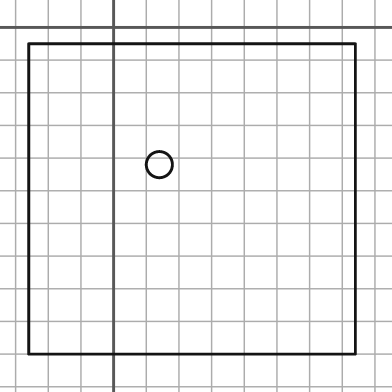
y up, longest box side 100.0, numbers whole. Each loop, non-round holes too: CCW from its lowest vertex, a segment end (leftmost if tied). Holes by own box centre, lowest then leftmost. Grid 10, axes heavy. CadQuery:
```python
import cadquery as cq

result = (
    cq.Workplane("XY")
    .moveTo(-26.0, -100.0)
    .lineTo(74.0, -100.0)
    .lineTo(74.0, -5.0)
    .lineTo(-26.0, -5.0)
    .close()
    .moveTo(14.0, -42.0)
    .circle(4.0)
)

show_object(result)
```